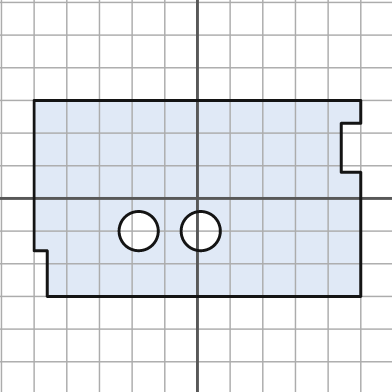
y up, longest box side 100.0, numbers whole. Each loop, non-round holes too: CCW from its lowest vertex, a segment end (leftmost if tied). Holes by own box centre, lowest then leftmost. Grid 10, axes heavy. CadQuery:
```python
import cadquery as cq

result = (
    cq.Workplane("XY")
    .moveTo(-46.0, -30.0)
    .lineTo(50.0, -30.0)
    .lineTo(50.0, 8.0)
    .lineTo(44.0, 8.0)
    .lineTo(44.0, 23.0)
    .lineTo(50.0, 23.0)
    .lineTo(50.0, 30.0)
    .lineTo(-50.0, 30.0)
    .lineTo(-50.0, -16.0)
    .lineTo(-46.0, -16.0)
    .close()
    .moveTo(-18.0, -10.0)
    .circle(6.0)
    .moveTo(1.0, -10.0)
    .circle(6.0)
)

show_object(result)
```